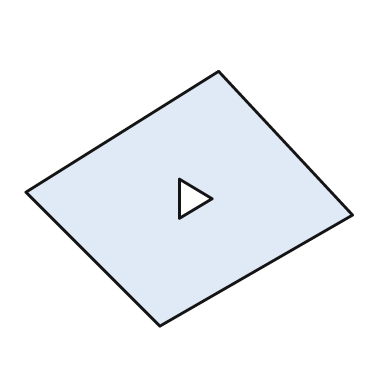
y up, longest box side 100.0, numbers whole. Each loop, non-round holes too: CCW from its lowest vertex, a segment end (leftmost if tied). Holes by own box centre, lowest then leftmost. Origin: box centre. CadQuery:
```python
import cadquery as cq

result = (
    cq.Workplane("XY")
    .moveTo(-9.0, -39.0)
    .lineTo(50.0, -5.0)
    .lineTo(9.0, 39.0)
    .lineTo(-50.0, 2.0)
    .close()
    .moveTo(-3.0, -6.0)
    .lineTo(7.0, 0.0)
    .lineTo(-3.0, 6.0)
    .close()
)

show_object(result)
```